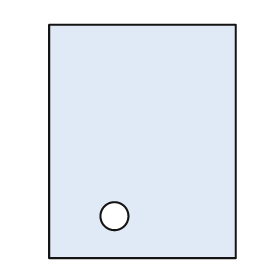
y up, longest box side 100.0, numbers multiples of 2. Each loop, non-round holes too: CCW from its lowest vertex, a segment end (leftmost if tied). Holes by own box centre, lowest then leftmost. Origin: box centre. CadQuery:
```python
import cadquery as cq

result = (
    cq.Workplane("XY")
    .moveTo(-40.0, -50.0)
    .lineTo(40.0, -50.0)
    .lineTo(40.0, 50.0)
    .lineTo(-40.0, 50.0)
    .close()
    .moveTo(-12.0, -32.0)
    .circle(6.0)
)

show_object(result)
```